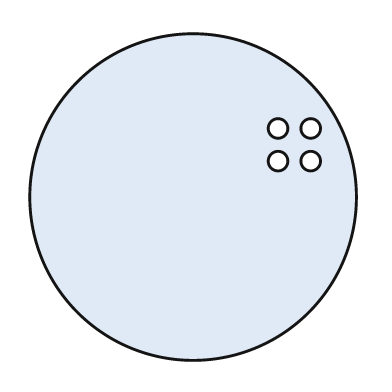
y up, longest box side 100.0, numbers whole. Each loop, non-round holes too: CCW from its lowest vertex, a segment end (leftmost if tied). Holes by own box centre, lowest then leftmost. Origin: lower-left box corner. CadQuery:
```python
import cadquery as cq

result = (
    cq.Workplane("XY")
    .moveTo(50.0, 50.0)
    .circle(50.0)
    .moveTo(76.0, 61.0)
    .circle(3.0)
    .moveTo(86.0, 61.0)
    .circle(3.0)
    .moveTo(76.0, 71.0)
    .circle(3.0)
    .moveTo(86.0, 71.0)
    .circle(3.0)
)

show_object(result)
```